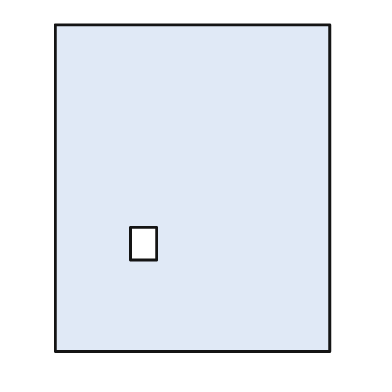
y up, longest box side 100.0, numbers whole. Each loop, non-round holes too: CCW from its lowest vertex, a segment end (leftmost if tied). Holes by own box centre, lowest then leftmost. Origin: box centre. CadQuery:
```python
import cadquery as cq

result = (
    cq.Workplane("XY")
    .moveTo(-42.0, -50.0)
    .lineTo(42.0, -50.0)
    .lineTo(42.0, 50.0)
    .lineTo(-42.0, 50.0)
    .close()
    .moveTo(-19.0, -22.0)
    .lineTo(-11.0, -22.0)
    .lineTo(-11.0, -12.0)
    .lineTo(-19.0, -12.0)
    .close()
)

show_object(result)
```